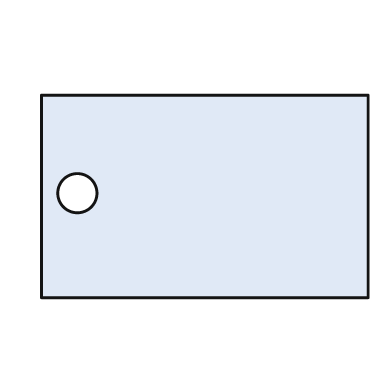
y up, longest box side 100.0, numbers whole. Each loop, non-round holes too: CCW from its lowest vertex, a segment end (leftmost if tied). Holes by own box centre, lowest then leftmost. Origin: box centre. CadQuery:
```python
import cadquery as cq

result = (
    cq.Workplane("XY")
    .moveTo(-50.0, -31.0)
    .lineTo(50.0, -31.0)
    .lineTo(50.0, 31.0)
    .lineTo(-50.0, 31.0)
    .close()
    .moveTo(-39.0, 1.0)
    .circle(6.0)
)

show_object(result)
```